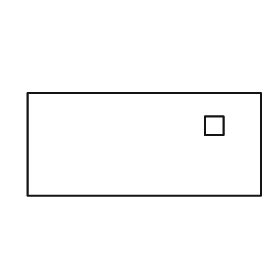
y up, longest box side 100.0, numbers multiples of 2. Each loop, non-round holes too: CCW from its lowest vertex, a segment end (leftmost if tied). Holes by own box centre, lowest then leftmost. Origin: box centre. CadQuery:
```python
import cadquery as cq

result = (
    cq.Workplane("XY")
    .moveTo(-50.0, -22.0)
    .lineTo(50.0, -22.0)
    .lineTo(50.0, 22.0)
    .lineTo(-50.0, 22.0)
    .close()
    .moveTo(26.0, 4.0)
    .lineTo(34.0, 4.0)
    .lineTo(34.0, 12.0)
    .lineTo(26.0, 12.0)
    .close()
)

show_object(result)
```